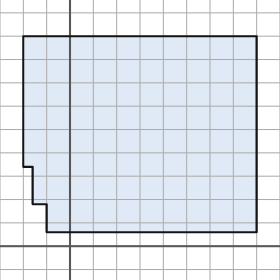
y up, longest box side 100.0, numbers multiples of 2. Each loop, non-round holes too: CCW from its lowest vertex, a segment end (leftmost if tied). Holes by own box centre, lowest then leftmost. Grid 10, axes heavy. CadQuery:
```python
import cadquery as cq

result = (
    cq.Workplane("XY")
    .moveTo(-10.0, 6.0)
    .lineTo(80.0, 6.0)
    .lineTo(80.0, 90.0)
    .lineTo(-20.0, 90.0)
    .lineTo(-20.0, 34.0)
    .lineTo(-16.0, 34.0)
    .lineTo(-16.0, 18.0)
    .lineTo(-10.0, 18.0)
    .close()
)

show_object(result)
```